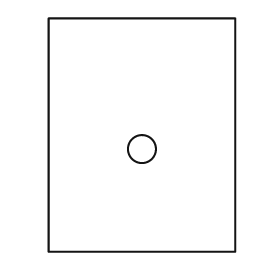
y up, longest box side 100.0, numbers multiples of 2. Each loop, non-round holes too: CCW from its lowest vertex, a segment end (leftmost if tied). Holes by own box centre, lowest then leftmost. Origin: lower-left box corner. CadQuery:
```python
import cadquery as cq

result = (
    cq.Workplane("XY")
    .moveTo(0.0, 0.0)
    .lineTo(80.0, 0.0)
    .lineTo(80.0, 100.0)
    .lineTo(0.0, 100.0)
    .close()
    .moveTo(40.0, 44.0)
    .circle(6.0)
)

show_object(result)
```